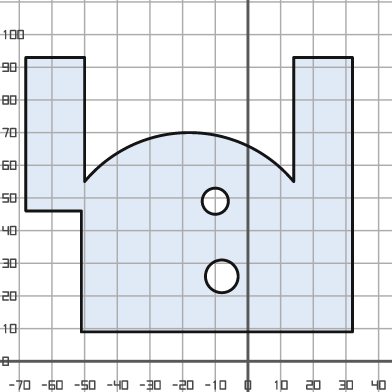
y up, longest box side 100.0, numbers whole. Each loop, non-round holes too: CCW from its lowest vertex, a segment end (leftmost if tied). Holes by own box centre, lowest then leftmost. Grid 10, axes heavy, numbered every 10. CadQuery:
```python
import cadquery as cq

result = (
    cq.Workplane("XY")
    .moveTo(-51.0, 9.0)
    .lineTo(32.0, 9.0)
    .lineTo(32.0, 93.0)
    .lineTo(14.0, 93.0)
    .lineTo(14.0, 55.0)
    .threePointArc((-18.0, 70.0), (-50.0, 55.0))
    .lineTo(-50.0, 93.0)
    .lineTo(-68.0, 93.0)
    .lineTo(-68.0, 46.0)
    .lineTo(-51.0, 46.0)
    .close()
    .moveTo(-8.0, 26.0)
    .circle(5.0)
    .moveTo(-10.0, 49.0)
    .circle(4.0)
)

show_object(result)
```